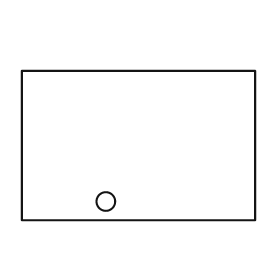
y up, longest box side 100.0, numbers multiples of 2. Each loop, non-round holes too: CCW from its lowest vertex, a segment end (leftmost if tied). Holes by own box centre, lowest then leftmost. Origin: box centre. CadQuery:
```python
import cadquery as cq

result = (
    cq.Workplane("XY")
    .moveTo(-50.0, -32.0)
    .lineTo(50.0, -32.0)
    .lineTo(50.0, 32.0)
    .lineTo(-50.0, 32.0)
    .close()
    .moveTo(-14.0, -24.0)
    .circle(4.0)
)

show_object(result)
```